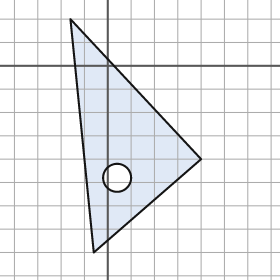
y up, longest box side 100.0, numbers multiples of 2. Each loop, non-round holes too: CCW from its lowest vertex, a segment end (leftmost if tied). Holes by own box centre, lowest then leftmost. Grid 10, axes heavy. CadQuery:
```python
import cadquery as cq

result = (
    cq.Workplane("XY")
    .moveTo(-6.0, -80.0)
    .lineTo(40.0, -40.0)
    .lineTo(-16.0, 20.0)
    .close()
    .moveTo(4.0, -48.0)
    .circle(6.0)
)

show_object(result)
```